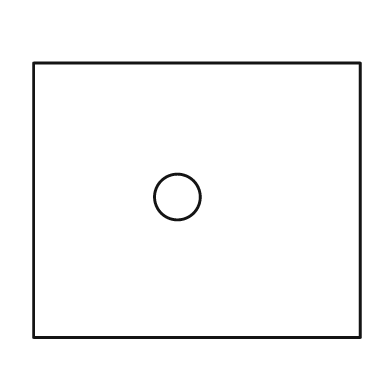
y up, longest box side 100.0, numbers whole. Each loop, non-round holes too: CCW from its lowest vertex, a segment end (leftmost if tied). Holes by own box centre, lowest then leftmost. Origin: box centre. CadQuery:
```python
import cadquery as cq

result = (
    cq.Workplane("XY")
    .moveTo(-50.0, -42.0)
    .lineTo(50.0, -42.0)
    .lineTo(50.0, 42.0)
    .lineTo(-50.0, 42.0)
    .close()
    .moveTo(-6.0, 1.0)
    .circle(7.0)
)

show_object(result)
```